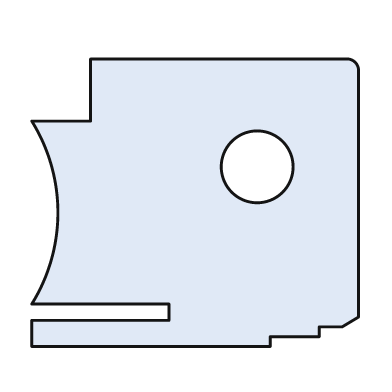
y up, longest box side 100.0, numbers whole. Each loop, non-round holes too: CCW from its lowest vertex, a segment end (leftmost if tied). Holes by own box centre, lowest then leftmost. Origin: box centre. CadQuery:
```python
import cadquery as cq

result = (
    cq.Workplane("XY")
    .moveTo(-50.0, -44.0)
    .lineTo(23.0, -44.0)
    .lineTo(23.0, -41.0)
    .lineTo(38.0, -41.0)
    .lineTo(38.0, -38.0)
    .lineTo(45.0, -38.0)
    .lineTo(50.0, -35.0)
    .lineTo(50.0, 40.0)
    .threePointArc((49.0, 43.0), (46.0, 44.0))
    .lineTo(-32.0, 44.0)
    .lineTo(-32.0, 25.0)
    .lineTo(-50.0, 25.0)
    .threePointArc((-42.0, -3.0), (-50.0, -31.0))
    .lineTo(-8.0, -31.0)
    .lineTo(-8.0, -36.0)
    .lineTo(-50.0, -36.0)
    .close()
    .moveTo(19.0, 11.0)
    .circle(11.0)
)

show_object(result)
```